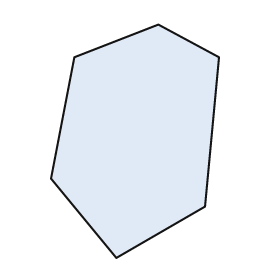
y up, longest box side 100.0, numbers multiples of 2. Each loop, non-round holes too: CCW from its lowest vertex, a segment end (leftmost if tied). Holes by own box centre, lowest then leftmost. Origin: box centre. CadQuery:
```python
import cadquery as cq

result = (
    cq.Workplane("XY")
    .moveTo(-8.0, -50.0)
    .lineTo(30.0, -28.0)
    .lineTo(36.0, 36.0)
    .lineTo(10.0, 50.0)
    .lineTo(-26.0, 36.0)
    .lineTo(-36.0, -16.0)
    .close()
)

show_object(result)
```